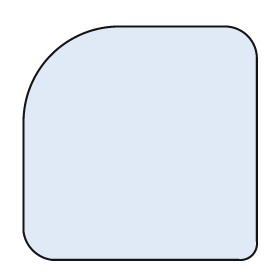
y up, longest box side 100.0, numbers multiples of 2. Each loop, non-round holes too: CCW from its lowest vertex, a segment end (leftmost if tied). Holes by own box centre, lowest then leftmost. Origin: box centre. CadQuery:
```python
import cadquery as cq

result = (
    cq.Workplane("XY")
    .moveTo(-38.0, -50.0)
    .lineTo(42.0, -50.0)
    .threePointArc((48.0, -48.0), (50.0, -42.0))
    .lineTo(50.0, 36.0)
    .threePointArc((46.0, 46.0), (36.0, 50.0))
    .lineTo(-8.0, 50.0)
    .threePointArc((-38.0, 38.0), (-50.0, 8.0))
    .lineTo(-50.0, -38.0)
    .threePointArc((-46.0, -46.0), (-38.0, -50.0))
    .close()
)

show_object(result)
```